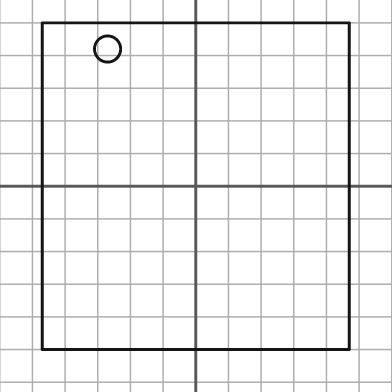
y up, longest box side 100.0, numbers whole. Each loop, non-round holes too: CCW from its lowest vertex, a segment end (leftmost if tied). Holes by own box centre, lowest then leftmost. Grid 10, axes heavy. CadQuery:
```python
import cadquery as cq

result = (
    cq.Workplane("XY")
    .moveTo(-47.0, -50.0)
    .lineTo(47.0, -50.0)
    .lineTo(47.0, 50.0)
    .lineTo(-47.0, 50.0)
    .close()
    .moveTo(-27.0, 42.0)
    .circle(4.0)
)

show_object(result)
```